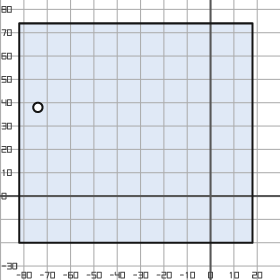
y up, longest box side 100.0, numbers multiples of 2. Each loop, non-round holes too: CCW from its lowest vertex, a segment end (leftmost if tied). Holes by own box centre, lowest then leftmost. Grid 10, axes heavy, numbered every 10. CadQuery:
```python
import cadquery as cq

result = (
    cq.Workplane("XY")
    .moveTo(-82.0, -20.0)
    .lineTo(18.0, -20.0)
    .lineTo(18.0, 74.0)
    .lineTo(-82.0, 74.0)
    .close()
    .moveTo(-74.0, 38.0)
    .circle(2.0)
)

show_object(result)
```